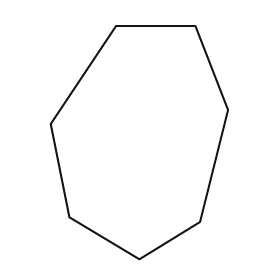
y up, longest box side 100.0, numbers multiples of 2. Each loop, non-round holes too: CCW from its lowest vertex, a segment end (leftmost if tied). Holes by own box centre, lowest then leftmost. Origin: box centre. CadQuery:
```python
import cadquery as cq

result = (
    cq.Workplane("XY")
    .moveTo(0.0, -50.0)
    .lineTo(26.0, -34.0)
    .lineTo(38.0, 14.0)
    .lineTo(24.0, 50.0)
    .lineTo(-10.0, 50.0)
    .lineTo(-38.0, 8.0)
    .lineTo(-30.0, -32.0)
    .close()
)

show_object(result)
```